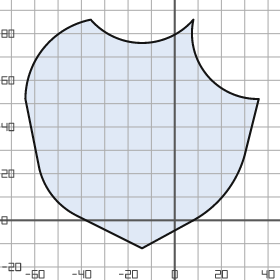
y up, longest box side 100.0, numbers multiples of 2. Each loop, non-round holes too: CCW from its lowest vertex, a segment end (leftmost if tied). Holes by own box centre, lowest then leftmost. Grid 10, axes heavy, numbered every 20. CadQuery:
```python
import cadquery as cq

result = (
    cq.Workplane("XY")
    .moveTo(-14.0, -12.0)
    .lineTo(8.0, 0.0)
    .threePointArc((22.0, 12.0), (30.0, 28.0))
    .lineTo(36.0, 52.0)
    .threePointArc((14.0, 62.0), (8.0, 86.0))
    .threePointArc((-14.0, 76.0), (-36.0, 86.0))
    .threePointArc((-56.0, 74.0), (-64.0, 52.0))
    .lineTo(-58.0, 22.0)
    .threePointArc((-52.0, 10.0), (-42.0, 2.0))
    .close()
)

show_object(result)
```